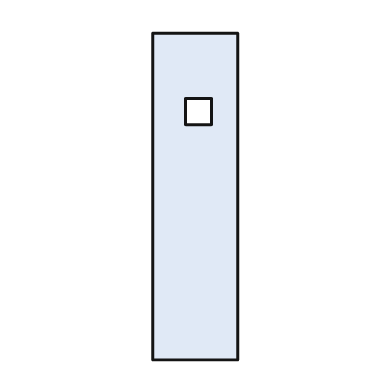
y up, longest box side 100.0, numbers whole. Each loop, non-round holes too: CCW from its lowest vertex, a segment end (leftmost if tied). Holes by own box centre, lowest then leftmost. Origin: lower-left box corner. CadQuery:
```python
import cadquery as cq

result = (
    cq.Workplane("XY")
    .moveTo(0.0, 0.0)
    .lineTo(26.0, 0.0)
    .lineTo(26.0, 100.0)
    .lineTo(0.0, 100.0)
    .close()
    .moveTo(10.0, 72.0)
    .lineTo(18.0, 72.0)
    .lineTo(18.0, 80.0)
    .lineTo(10.0, 80.0)
    .close()
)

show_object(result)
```